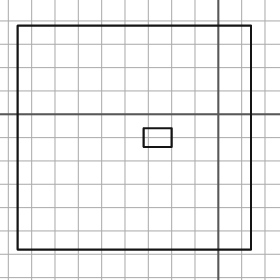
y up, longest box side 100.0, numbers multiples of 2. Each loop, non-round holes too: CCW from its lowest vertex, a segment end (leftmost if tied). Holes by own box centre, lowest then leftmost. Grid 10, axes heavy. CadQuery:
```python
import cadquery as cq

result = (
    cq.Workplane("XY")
    .moveTo(-86.0, -58.0)
    .lineTo(14.0, -58.0)
    .lineTo(14.0, 38.0)
    .lineTo(-86.0, 38.0)
    .close()
    .moveTo(-32.0, -14.0)
    .lineTo(-20.0, -14.0)
    .lineTo(-20.0, -6.0)
    .lineTo(-32.0, -6.0)
    .close()
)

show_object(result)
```